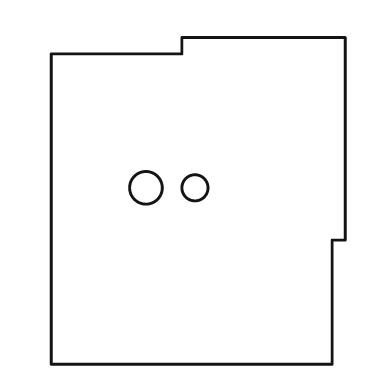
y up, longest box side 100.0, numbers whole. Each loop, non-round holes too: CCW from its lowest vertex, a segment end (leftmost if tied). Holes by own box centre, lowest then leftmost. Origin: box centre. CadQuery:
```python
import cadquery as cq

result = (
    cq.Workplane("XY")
    .moveTo(-45.0, -50.0)
    .lineTo(41.0, -50.0)
    .lineTo(41.0, -12.0)
    .lineTo(45.0, -12.0)
    .lineTo(45.0, 50.0)
    .lineTo(-5.0, 50.0)
    .lineTo(-5.0, 45.0)
    .lineTo(-45.0, 45.0)
    .close()
    .moveTo(-16.0, 4.0)
    .circle(5.0)
    .moveTo(-1.0, 4.0)
    .circle(4.0)
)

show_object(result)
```